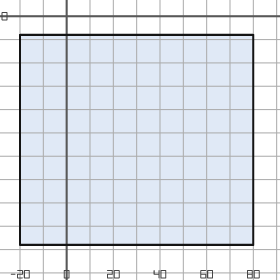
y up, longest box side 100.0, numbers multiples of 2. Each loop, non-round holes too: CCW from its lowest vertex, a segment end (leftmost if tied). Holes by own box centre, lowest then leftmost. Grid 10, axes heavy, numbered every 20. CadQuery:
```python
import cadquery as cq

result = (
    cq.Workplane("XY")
    .moveTo(-20.0, -98.0)
    .lineTo(80.0, -98.0)
    .lineTo(80.0, -8.0)
    .lineTo(-20.0, -8.0)
    .close()
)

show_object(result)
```